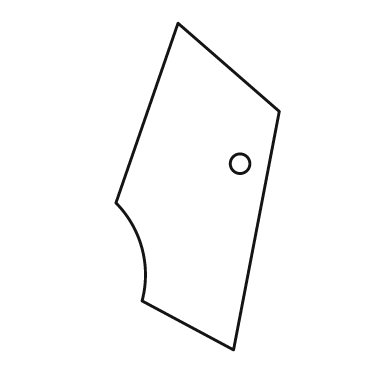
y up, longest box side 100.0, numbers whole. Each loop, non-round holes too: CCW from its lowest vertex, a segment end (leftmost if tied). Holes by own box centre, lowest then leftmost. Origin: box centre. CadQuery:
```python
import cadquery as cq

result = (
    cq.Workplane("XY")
    .moveTo(11.0, -50.0)
    .lineTo(25.0, 23.0)
    .lineTo(-6.0, 50.0)
    .lineTo(-25.0, -5.0)
    .threePointArc((-17.0, -19.0), (-17.0, -35.0))
    .close()
    .moveTo(13.0, 7.0)
    .circle(3.0)
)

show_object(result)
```